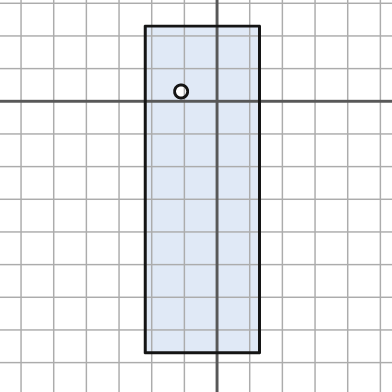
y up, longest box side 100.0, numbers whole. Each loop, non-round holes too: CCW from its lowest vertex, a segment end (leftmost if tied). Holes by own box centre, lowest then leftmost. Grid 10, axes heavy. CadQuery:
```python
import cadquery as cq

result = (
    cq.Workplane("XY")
    .moveTo(-22.0, -77.0)
    .lineTo(13.0, -77.0)
    .lineTo(13.0, 23.0)
    .lineTo(-22.0, 23.0)
    .close()
    .moveTo(-11.0, 3.0)
    .circle(2.0)
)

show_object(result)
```